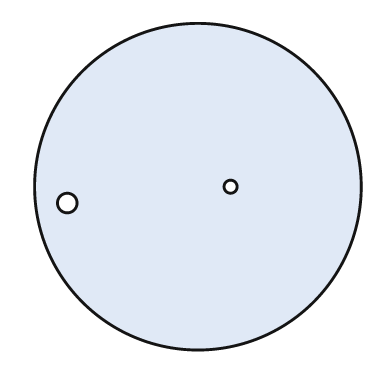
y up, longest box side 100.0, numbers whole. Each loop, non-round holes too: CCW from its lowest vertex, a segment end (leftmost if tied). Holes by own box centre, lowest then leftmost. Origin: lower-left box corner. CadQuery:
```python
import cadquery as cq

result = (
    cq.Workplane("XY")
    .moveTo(50.0, 50.0)
    .circle(50.0)
    .moveTo(10.0, 45.0)
    .circle(3.0)
    .moveTo(60.0, 50.0)
    .circle(2.0)
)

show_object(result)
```